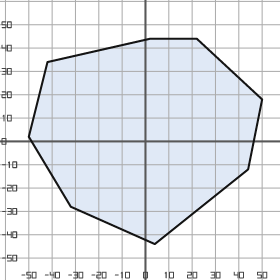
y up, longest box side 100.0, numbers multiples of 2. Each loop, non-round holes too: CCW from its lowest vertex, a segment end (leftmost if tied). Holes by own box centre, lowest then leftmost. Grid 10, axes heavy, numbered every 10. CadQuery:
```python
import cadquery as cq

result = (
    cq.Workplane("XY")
    .moveTo(4.0, -44.0)
    .lineTo(44.0, -12.0)
    .lineTo(50.0, 18.0)
    .lineTo(22.0, 44.0)
    .lineTo(2.0, 44.0)
    .lineTo(-42.0, 34.0)
    .lineTo(-50.0, 2.0)
    .lineTo(-32.0, -28.0)
    .close()
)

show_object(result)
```